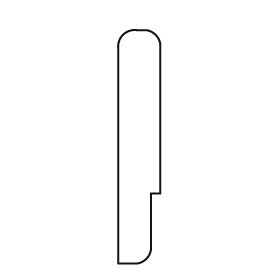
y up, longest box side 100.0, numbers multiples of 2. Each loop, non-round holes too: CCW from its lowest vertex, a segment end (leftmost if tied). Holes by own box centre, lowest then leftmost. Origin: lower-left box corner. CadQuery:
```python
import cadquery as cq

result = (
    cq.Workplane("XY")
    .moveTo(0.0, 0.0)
    .lineTo(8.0, 0.0)
    .threePointArc((12.0, 2.0), (14.0, 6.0))
    .lineTo(14.0, 30.0)
    .lineTo(18.0, 30.0)
    .lineTo(18.0, 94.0)
    .threePointArc((16.0, 98.0), (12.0, 100.0))
    .lineTo(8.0, 100.0)
    .threePointArc((2.0, 98.0), (0.0, 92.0))
    .close()
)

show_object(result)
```